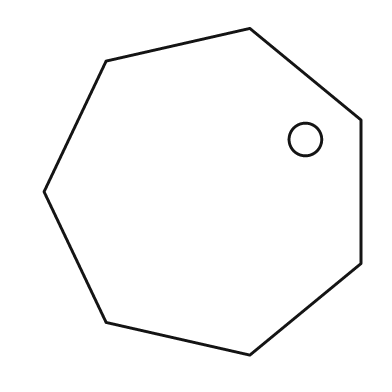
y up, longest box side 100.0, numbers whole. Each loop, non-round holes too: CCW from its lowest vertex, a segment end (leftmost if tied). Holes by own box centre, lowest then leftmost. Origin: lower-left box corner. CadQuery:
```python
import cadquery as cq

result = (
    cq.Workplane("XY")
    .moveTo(63.0, 0.0)
    .lineTo(97.0, 28.0)
    .lineTo(97.0, 72.0)
    .lineTo(63.0, 100.0)
    .lineTo(19.0, 90.0)
    .lineTo(0.0, 50.0)
    .lineTo(19.0, 10.0)
    .close()
    .moveTo(80.0, 66.0)
    .circle(5.0)
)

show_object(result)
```